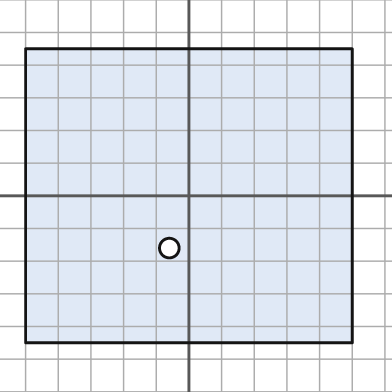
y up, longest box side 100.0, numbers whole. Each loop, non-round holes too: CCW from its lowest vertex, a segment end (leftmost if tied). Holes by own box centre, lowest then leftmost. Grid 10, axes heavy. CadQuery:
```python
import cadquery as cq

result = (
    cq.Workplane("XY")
    .moveTo(-50.0, -45.0)
    .lineTo(50.0, -45.0)
    .lineTo(50.0, 45.0)
    .lineTo(-50.0, 45.0)
    .close()
    .moveTo(-6.0, -16.0)
    .circle(3.0)
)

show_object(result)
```